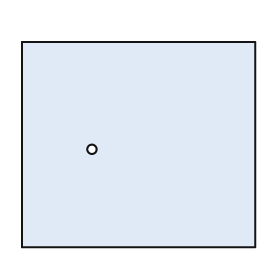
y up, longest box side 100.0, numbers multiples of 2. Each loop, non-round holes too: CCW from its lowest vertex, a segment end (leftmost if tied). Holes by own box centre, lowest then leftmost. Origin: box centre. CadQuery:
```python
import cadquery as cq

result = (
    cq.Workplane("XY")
    .moveTo(-50.0, -44.0)
    .lineTo(50.0, -44.0)
    .lineTo(50.0, 44.0)
    .lineTo(-50.0, 44.0)
    .close()
    .moveTo(-20.0, -2.0)
    .circle(2.0)
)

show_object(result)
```